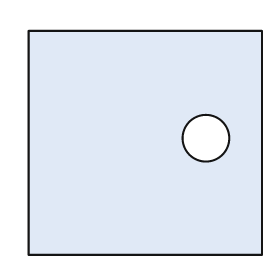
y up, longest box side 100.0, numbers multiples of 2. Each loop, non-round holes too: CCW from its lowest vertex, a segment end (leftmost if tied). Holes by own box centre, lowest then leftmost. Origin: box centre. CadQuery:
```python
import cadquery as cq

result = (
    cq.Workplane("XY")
    .moveTo(-50.0, -48.0)
    .lineTo(50.0, -48.0)
    .lineTo(50.0, 48.0)
    .lineTo(-50.0, 48.0)
    .close()
    .moveTo(26.0, 2.0)
    .circle(10.0)
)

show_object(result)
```